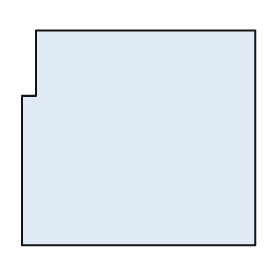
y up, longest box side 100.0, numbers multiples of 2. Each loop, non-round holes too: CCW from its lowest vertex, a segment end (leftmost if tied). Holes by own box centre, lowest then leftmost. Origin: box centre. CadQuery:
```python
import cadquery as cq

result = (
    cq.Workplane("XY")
    .moveTo(-50.0, -46.0)
    .lineTo(50.0, -46.0)
    .lineTo(50.0, 46.0)
    .lineTo(-44.0, 46.0)
    .lineTo(-44.0, 18.0)
    .lineTo(-50.0, 18.0)
    .close()
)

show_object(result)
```